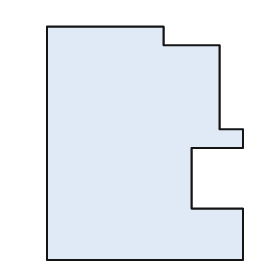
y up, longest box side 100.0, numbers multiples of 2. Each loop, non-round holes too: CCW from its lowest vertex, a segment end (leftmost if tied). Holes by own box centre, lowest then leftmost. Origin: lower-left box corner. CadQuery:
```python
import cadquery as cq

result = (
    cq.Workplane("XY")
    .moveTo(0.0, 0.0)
    .lineTo(84.0, 0.0)
    .lineTo(84.0, 22.0)
    .lineTo(62.0, 22.0)
    .lineTo(62.0, 48.0)
    .lineTo(84.0, 48.0)
    .lineTo(84.0, 56.0)
    .lineTo(74.0, 56.0)
    .lineTo(74.0, 92.0)
    .lineTo(50.0, 92.0)
    .lineTo(50.0, 100.0)
    .lineTo(0.0, 100.0)
    .close()
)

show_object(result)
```